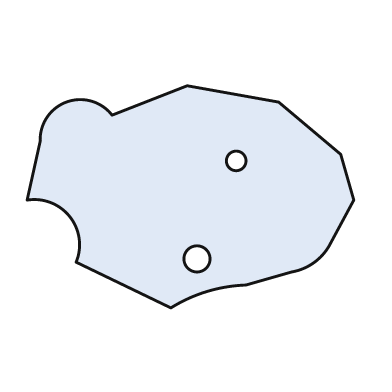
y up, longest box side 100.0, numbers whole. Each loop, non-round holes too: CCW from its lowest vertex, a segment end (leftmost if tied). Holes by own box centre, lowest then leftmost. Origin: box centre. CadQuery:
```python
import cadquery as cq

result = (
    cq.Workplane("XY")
    .moveTo(-6.0, -34.0)
    .threePointArc((5.0, -29.0), (17.0, -27.0))
    .lineTo(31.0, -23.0)
    .threePointArc((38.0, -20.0), (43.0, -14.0))
    .lineTo(50.0, -1.0)
    .lineTo(46.0, 13.0)
    .lineTo(27.0, 29.0)
    .lineTo(-1.0, 34.0)
    .lineTo(-24.0, 25.0)
    .threePointArc((-38.0, 29.0), (-46.0, 17.0))
    .lineTo(-50.0, -1.0)
    .threePointArc((-37.0, -6.0), (-35.0, -20.0))
    .close()
    .moveTo(2.0, -19.0)
    .circle(4.0)
    .moveTo(14.0, 11.0)
    .circle(3.0)
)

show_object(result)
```